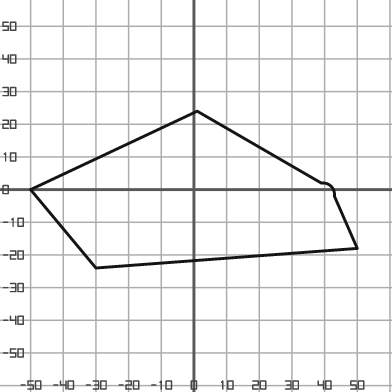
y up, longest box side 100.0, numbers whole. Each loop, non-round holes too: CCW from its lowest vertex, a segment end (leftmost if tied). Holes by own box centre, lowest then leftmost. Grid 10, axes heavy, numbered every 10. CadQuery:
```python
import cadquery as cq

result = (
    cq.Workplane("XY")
    .moveTo(-30.0, -24.0)
    .lineTo(50.0, -18.0)
    .lineTo(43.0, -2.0)
    .threePointArc((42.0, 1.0), (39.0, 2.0))
    .lineTo(1.0, 24.0)
    .lineTo(-50.0, 0.0)
    .close()
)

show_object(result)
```